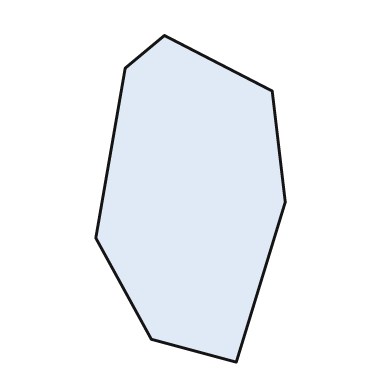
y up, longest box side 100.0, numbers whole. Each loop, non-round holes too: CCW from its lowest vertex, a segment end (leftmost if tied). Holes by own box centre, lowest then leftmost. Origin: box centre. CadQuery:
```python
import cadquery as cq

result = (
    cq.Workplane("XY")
    .moveTo(14.0, -50.0)
    .lineTo(29.0, -1.0)
    .lineTo(25.0, 33.0)
    .lineTo(-8.0, 50.0)
    .lineTo(-20.0, 40.0)
    .lineTo(-29.0, -12.0)
    .lineTo(-12.0, -43.0)
    .close()
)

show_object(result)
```